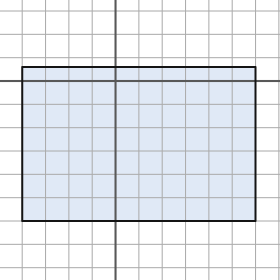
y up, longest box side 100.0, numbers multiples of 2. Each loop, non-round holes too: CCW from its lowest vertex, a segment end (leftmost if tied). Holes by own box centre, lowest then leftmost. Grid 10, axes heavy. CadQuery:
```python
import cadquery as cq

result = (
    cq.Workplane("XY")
    .moveTo(-40.0, -60.0)
    .lineTo(60.0, -60.0)
    .lineTo(60.0, 6.0)
    .lineTo(-40.0, 6.0)
    .close()
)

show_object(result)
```